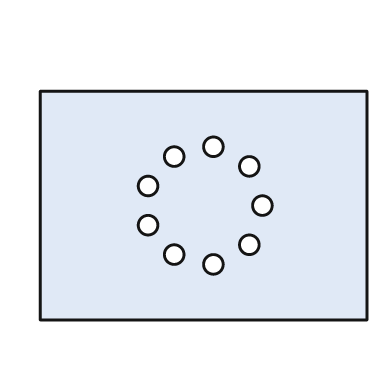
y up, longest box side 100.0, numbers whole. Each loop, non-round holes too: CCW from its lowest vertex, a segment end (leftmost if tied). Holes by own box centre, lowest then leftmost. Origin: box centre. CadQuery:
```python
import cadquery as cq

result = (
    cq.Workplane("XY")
    .moveTo(-50.0, -35.0)
    .lineTo(50.0, -35.0)
    .lineTo(50.0, 35.0)
    .lineTo(-50.0, 35.0)
    .close()
    .moveTo(3.0, -18.0)
    .circle(3.0)
    .moveTo(-9.0, -15.0)
    .circle(3.0)
    .moveTo(14.0, -12.0)
    .circle(3.0)
    .moveTo(-17.0, -6.0)
    .circle(3.0)
    .moveTo(18.0, 0.0)
    .circle(3.0)
    .moveTo(-17.0, 6.0)
    .circle(3.0)
    .moveTo(14.0, 12.0)
    .circle(3.0)
    .moveTo(-9.0, 15.0)
    .circle(3.0)
    .moveTo(3.0, 18.0)
    .circle(3.0)
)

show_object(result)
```